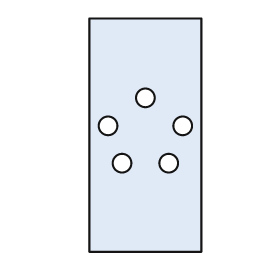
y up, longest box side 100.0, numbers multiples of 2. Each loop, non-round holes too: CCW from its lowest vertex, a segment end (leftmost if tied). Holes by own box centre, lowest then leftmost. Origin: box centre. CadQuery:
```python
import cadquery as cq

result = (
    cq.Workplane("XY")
    .moveTo(-24.0, -50.0)
    .lineTo(24.0, -50.0)
    .lineTo(24.0, 50.0)
    .lineTo(-24.0, 50.0)
    .close()
    .moveTo(-10.0, -12.0)
    .circle(4.0)
    .moveTo(10.0, -12.0)
    .circle(4.0)
    .moveTo(-16.0, 4.0)
    .circle(4.0)
    .moveTo(16.0, 4.0)
    .circle(4.0)
    .moveTo(0.0, 16.0)
    .circle(4.0)
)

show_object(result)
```